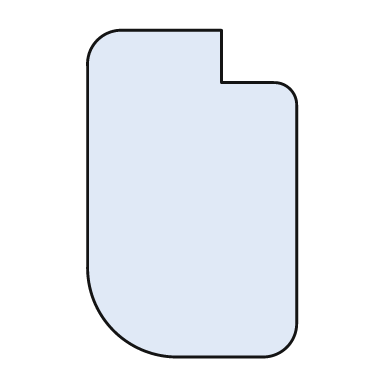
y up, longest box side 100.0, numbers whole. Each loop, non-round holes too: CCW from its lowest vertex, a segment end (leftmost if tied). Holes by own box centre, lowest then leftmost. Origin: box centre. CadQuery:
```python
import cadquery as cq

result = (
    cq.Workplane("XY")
    .moveTo(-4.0, -50.0)
    .lineTo(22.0, -50.0)
    .threePointArc((29.0, -47.0), (32.0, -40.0))
    .lineTo(32.0, 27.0)
    .threePointArc((30.0, 32.0), (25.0, 34.0))
    .lineTo(9.0, 34.0)
    .lineTo(9.0, 50.0)
    .lineTo(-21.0, 50.0)
    .threePointArc((-29.0, 47.0), (-32.0, 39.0))
    .lineTo(-32.0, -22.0)
    .threePointArc((-24.0, -42.0), (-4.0, -50.0))
    .close()
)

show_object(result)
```